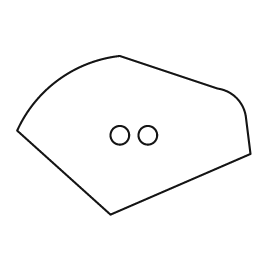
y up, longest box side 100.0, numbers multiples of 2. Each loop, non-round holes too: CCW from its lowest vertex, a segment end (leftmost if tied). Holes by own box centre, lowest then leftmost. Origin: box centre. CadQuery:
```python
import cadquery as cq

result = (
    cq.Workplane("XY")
    .moveTo(-10.0, -34.0)
    .lineTo(50.0, -8.0)
    .lineTo(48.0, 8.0)
    .threePointArc((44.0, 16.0), (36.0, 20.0))
    .lineTo(-6.0, 34.0)
    .threePointArc((-32.0, 24.0), (-50.0, 2.0))
    .close()
    .moveTo(-6.0, 0.0)
    .circle(4.0)
    .moveTo(6.0, 0.0)
    .circle(4.0)
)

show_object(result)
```